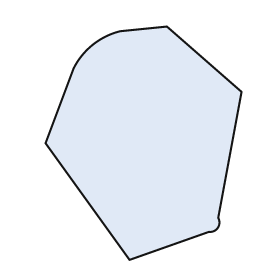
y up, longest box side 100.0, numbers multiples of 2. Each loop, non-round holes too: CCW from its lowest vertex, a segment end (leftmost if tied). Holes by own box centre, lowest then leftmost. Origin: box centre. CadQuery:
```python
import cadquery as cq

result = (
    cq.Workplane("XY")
    .moveTo(-6.0, -50.0)
    .lineTo(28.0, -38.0)
    .threePointArc((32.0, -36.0), (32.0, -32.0))
    .lineTo(42.0, 22.0)
    .lineTo(10.0, 50.0)
    .lineTo(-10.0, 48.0)
    .threePointArc((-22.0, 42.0), (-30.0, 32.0))
    .lineTo(-42.0, 0.0)
    .close()
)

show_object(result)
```